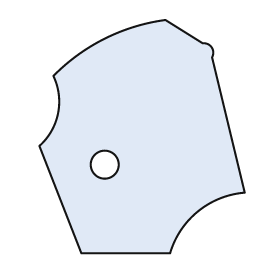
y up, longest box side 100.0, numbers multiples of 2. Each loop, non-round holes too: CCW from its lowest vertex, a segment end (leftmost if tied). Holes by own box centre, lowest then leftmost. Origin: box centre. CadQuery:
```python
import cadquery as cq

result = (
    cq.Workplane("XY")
    .moveTo(-26.0, -50.0)
    .lineTo(12.0, -50.0)
    .threePointArc((24.0, -32.0), (44.0, -24.0))
    .lineTo(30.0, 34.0)
    .threePointArc((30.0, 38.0), (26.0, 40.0))
    .lineTo(10.0, 50.0)
    .threePointArc((-16.0, 42.0), (-38.0, 26.0))
    .threePointArc((-36.0, 10.0), (-44.0, -4.0))
    .close()
    .moveTo(-16.0, -12.0)
    .circle(6.0)
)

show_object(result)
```